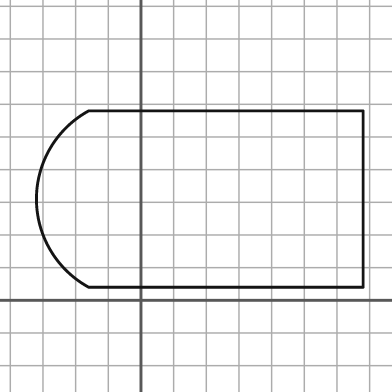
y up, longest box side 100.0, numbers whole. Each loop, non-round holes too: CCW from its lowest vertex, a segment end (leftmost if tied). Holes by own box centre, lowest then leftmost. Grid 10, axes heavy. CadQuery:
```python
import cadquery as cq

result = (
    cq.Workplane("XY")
    .moveTo(-16.0, 4.0)
    .lineTo(68.0, 4.0)
    .lineTo(68.0, 58.0)
    .lineTo(-16.0, 58.0)
    .threePointArc((-32.0, 31.0), (-16.0, 4.0))
    .close()
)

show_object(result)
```